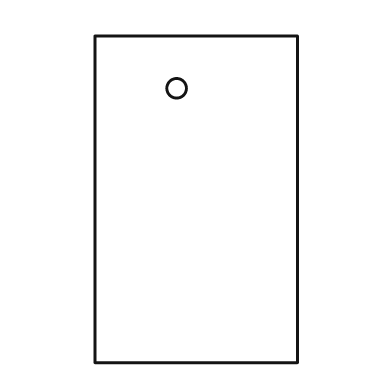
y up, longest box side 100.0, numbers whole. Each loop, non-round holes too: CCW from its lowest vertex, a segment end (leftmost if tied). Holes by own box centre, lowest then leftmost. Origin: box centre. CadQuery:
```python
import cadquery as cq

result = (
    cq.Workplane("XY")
    .moveTo(-31.0, -50.0)
    .lineTo(31.0, -50.0)
    .lineTo(31.0, 50.0)
    .lineTo(-31.0, 50.0)
    .close()
    .moveTo(-6.0, 34.0)
    .circle(3.0)
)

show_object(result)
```